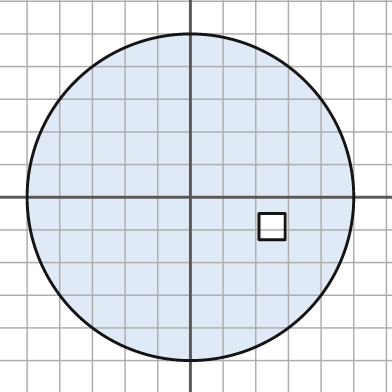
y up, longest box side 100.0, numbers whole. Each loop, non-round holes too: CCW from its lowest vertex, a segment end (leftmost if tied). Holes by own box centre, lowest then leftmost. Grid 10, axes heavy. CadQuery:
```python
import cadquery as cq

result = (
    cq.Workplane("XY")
    .moveTo(0.0, 0.0)
    .circle(50.0)
    .moveTo(21.0, -13.0)
    .lineTo(29.0, -13.0)
    .lineTo(29.0, -5.0)
    .lineTo(21.0, -5.0)
    .close()
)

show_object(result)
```